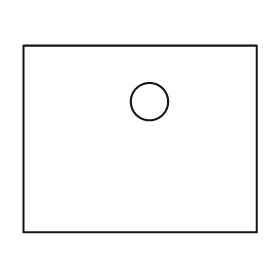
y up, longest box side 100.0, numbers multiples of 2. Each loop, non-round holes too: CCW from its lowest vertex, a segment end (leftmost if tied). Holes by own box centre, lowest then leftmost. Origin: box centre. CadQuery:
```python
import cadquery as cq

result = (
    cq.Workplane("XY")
    .moveTo(-50.0, -40.0)
    .lineTo(50.0, -40.0)
    .lineTo(50.0, 40.0)
    .lineTo(-50.0, 40.0)
    .close()
    .moveTo(4.0, 16.0)
    .circle(8.0)
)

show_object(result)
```